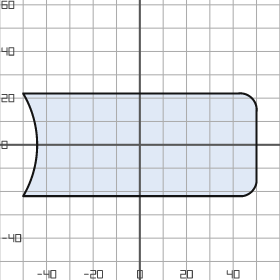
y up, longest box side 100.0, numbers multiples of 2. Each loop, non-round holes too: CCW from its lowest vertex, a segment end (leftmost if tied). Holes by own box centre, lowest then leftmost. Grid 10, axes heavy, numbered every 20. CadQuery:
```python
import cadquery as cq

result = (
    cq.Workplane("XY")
    .moveTo(-50.0, -22.0)
    .lineTo(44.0, -22.0)
    .threePointArc((48.0, -20.0), (50.0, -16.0))
    .lineTo(50.0, 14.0)
    .threePointArc((48.0, 20.0), (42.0, 22.0))
    .lineTo(-50.0, 22.0)
    .threePointArc((-44.0, 0.0), (-50.0, -22.0))
    .close()
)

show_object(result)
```